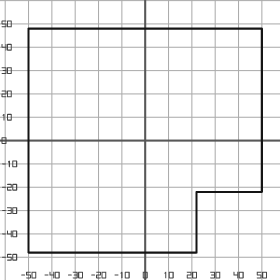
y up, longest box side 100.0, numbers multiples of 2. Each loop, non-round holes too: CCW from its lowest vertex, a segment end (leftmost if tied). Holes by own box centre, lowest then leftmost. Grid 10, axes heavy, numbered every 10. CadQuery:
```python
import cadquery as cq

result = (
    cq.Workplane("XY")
    .moveTo(-50.0, -48.0)
    .lineTo(22.0, -48.0)
    .lineTo(22.0, -22.0)
    .lineTo(50.0, -22.0)
    .lineTo(50.0, 48.0)
    .lineTo(-50.0, 48.0)
    .close()
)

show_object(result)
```